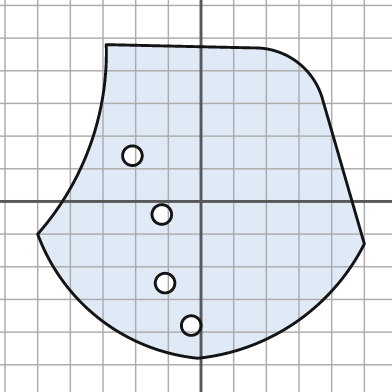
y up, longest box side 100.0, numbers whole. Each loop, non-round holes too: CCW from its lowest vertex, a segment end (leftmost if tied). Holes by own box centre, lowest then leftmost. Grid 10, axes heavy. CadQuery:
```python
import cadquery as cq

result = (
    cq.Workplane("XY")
    .moveTo(-1.0, -48.0)
    .threePointArc((29.0, -37.0), (50.0, -13.0))
    .lineTo(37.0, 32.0)
    .threePointArc((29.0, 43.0), (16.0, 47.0))
    .lineTo(-29.0, 48.0)
    .threePointArc((-34.0, 17.0), (-50.0, -10.0))
    .threePointArc((-31.0, -36.0), (-1.0, -48.0))
    .close()
    .moveTo(-3.0, -38.0)
    .circle(3.0)
    .moveTo(-11.0, -25.0)
    .circle(3.0)
    .moveTo(-12.0, -4.0)
    .circle(3.0)
    .moveTo(-21.0, 14.0)
    .circle(3.0)
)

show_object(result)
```